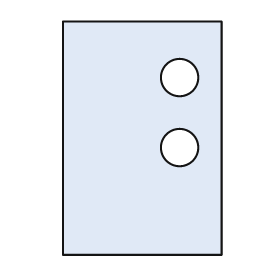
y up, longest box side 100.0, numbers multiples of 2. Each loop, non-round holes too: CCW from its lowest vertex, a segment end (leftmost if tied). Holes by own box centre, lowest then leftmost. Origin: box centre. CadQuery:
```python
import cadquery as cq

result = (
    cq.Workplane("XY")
    .moveTo(-34.0, -50.0)
    .lineTo(34.0, -50.0)
    .lineTo(34.0, 50.0)
    .lineTo(-34.0, 50.0)
    .close()
    .moveTo(16.0, -4.0)
    .circle(8.0)
    .moveTo(16.0, 26.0)
    .circle(8.0)
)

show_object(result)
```